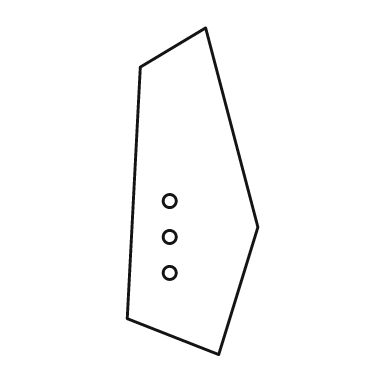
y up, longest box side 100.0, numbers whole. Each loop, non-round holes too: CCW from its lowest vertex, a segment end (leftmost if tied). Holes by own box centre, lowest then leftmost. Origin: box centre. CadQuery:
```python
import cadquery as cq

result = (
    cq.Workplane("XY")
    .moveTo(8.0, -50.0)
    .lineTo(20.0, -11.0)
    .lineTo(4.0, 50.0)
    .lineTo(-16.0, 38.0)
    .lineTo(-20.0, -39.0)
    .close()
    .moveTo(-7.0, -25.0)
    .circle(2.0)
    .moveTo(-7.0, -14.0)
    .circle(2.0)
    .moveTo(-7.0, -3.0)
    .circle(2.0)
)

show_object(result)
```